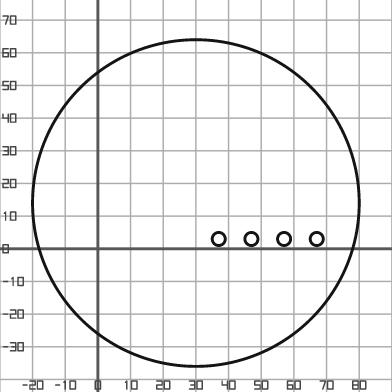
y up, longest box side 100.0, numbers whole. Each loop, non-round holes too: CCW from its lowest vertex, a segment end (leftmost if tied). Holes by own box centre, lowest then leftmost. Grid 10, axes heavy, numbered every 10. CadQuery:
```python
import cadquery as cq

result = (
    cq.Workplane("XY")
    .moveTo(30.0, 14.0)
    .circle(50.0)
    .moveTo(37.0, 3.0)
    .circle(2.0)
    .moveTo(47.0, 3.0)
    .circle(2.0)
    .moveTo(57.0, 3.0)
    .circle(2.0)
    .moveTo(67.0, 3.0)
    .circle(2.0)
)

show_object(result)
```